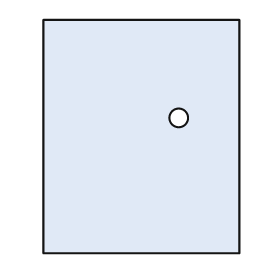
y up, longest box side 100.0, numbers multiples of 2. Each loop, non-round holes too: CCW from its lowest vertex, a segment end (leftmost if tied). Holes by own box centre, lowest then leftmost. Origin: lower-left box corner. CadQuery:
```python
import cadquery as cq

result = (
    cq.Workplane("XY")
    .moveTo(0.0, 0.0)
    .lineTo(84.0, 0.0)
    .lineTo(84.0, 100.0)
    .lineTo(0.0, 100.0)
    .close()
    .moveTo(58.0, 58.0)
    .circle(4.0)
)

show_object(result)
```